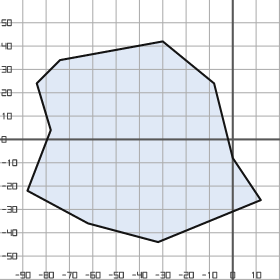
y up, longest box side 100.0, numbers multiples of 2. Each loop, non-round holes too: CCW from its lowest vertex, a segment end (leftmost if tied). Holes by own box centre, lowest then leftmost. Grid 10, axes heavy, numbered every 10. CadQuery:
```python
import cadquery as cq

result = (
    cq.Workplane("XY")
    .moveTo(-32.0, -44.0)
    .lineTo(12.0, -26.0)
    .lineTo(0.0, -8.0)
    .lineTo(-8.0, 24.0)
    .lineTo(-30.0, 42.0)
    .lineTo(-74.0, 34.0)
    .lineTo(-84.0, 24.0)
    .lineTo(-78.0, 4.0)
    .lineTo(-88.0, -22.0)
    .lineTo(-62.0, -36.0)
    .close()
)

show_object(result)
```